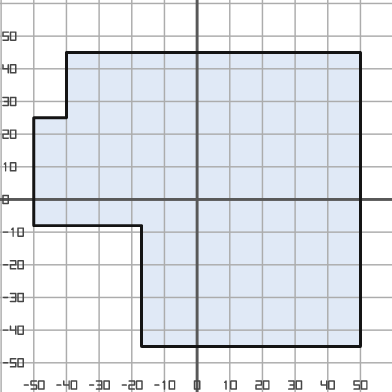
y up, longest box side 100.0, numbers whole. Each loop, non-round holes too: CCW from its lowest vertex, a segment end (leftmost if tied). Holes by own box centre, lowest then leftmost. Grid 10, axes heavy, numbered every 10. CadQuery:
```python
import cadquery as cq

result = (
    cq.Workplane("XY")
    .moveTo(-17.0, -45.0)
    .lineTo(50.0, -45.0)
    .lineTo(50.0, 45.0)
    .lineTo(-40.0, 45.0)
    .lineTo(-40.0, 25.0)
    .lineTo(-50.0, 25.0)
    .lineTo(-50.0, -8.0)
    .lineTo(-17.0, -8.0)
    .close()
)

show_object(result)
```